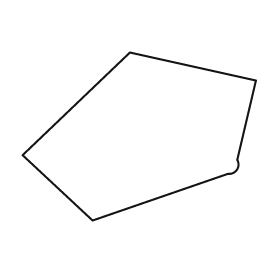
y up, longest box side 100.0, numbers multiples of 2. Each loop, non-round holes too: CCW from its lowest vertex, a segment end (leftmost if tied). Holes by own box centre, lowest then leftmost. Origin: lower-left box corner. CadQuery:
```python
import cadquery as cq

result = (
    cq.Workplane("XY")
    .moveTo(30.0, 0.0)
    .lineTo(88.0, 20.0)
    .threePointArc((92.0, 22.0), (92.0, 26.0))
    .lineTo(100.0, 60.0)
    .lineTo(46.0, 72.0)
    .lineTo(0.0, 28.0)
    .close()
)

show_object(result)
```